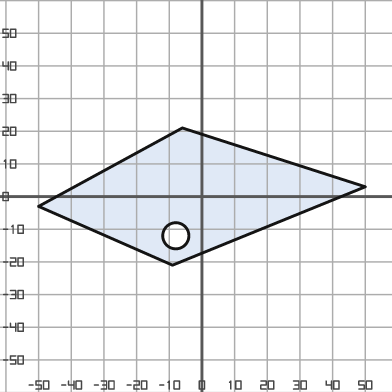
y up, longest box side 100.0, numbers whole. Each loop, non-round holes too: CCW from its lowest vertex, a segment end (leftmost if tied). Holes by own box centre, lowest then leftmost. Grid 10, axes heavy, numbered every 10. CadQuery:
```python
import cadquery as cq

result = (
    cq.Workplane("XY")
    .moveTo(-9.0, -21.0)
    .lineTo(50.0, 3.0)
    .lineTo(-6.0, 21.0)
    .lineTo(-50.0, -3.0)
    .close()
    .moveTo(-8.0, -12.0)
    .circle(4.0)
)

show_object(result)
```